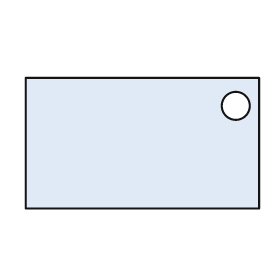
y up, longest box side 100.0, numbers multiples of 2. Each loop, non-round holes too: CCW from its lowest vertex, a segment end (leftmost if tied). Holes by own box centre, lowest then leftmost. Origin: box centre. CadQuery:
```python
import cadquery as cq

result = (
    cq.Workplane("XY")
    .moveTo(-50.0, -28.0)
    .lineTo(50.0, -28.0)
    .lineTo(50.0, 28.0)
    .lineTo(-50.0, 28.0)
    .close()
    .moveTo(40.0, 16.0)
    .circle(6.0)
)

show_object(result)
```